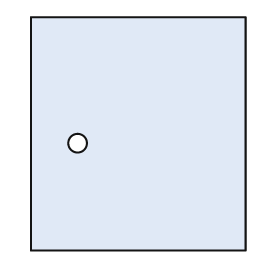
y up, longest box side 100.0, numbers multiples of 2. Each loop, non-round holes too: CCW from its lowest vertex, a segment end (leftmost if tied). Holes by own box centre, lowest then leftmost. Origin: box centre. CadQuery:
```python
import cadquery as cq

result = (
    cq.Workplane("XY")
    .moveTo(-46.0, -50.0)
    .lineTo(46.0, -50.0)
    .lineTo(46.0, 50.0)
    .lineTo(-46.0, 50.0)
    .close()
    .moveTo(-26.0, -4.0)
    .circle(4.0)
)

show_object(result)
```